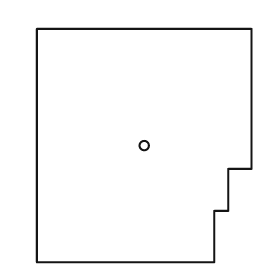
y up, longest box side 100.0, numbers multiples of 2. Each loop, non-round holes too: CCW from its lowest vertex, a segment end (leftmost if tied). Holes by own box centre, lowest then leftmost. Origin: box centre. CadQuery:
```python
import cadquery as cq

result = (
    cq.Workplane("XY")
    .moveTo(-46.0, -50.0)
    .lineTo(30.0, -50.0)
    .lineTo(30.0, -28.0)
    .lineTo(36.0, -28.0)
    .lineTo(36.0, -10.0)
    .lineTo(46.0, -10.0)
    .lineTo(46.0, 50.0)
    .lineTo(-46.0, 50.0)
    .close()
    .moveTo(0.0, 0.0)
    .circle(2.0)
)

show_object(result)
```